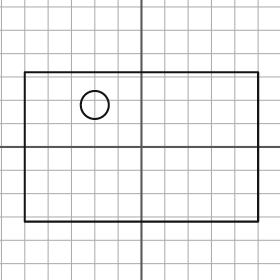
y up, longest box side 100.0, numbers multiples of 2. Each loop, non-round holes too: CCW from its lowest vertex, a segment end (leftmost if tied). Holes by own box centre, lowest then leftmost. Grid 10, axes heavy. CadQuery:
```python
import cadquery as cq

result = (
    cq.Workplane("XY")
    .moveTo(-50.0, -32.0)
    .lineTo(50.0, -32.0)
    .lineTo(50.0, 32.0)
    .lineTo(-50.0, 32.0)
    .close()
    .moveTo(-20.0, 18.0)
    .circle(6.0)
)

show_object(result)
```